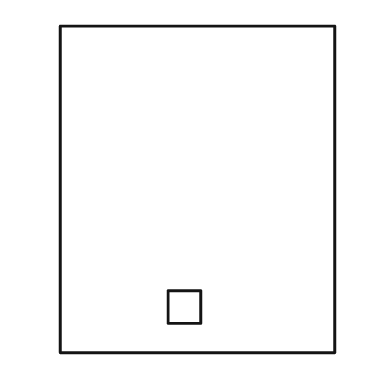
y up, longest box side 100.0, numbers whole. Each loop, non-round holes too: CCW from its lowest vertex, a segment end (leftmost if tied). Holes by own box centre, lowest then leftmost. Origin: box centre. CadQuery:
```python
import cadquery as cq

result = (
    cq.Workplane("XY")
    .moveTo(-42.0, -50.0)
    .lineTo(42.0, -50.0)
    .lineTo(42.0, 50.0)
    .lineTo(-42.0, 50.0)
    .close()
    .moveTo(-9.0, -41.0)
    .lineTo(1.0, -41.0)
    .lineTo(1.0, -31.0)
    .lineTo(-9.0, -31.0)
    .close()
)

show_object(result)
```